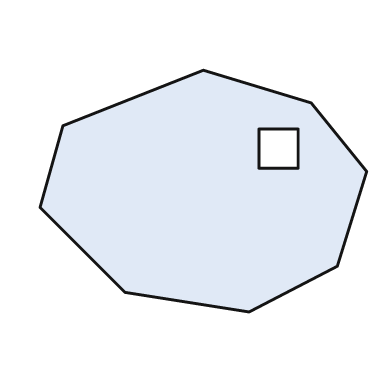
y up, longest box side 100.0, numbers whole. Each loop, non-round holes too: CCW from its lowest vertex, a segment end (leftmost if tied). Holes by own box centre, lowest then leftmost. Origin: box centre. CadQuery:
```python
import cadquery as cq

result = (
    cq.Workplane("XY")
    .moveTo(14.0, -37.0)
    .lineTo(41.0, -23.0)
    .lineTo(50.0, 6.0)
    .lineTo(33.0, 27.0)
    .lineTo(0.0, 37.0)
    .lineTo(-43.0, 20.0)
    .lineTo(-50.0, -5.0)
    .lineTo(-24.0, -31.0)
    .close()
    .moveTo(17.0, 7.0)
    .lineTo(29.0, 7.0)
    .lineTo(29.0, 19.0)
    .lineTo(17.0, 19.0)
    .close()
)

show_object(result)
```